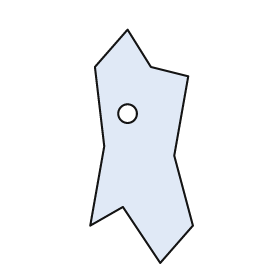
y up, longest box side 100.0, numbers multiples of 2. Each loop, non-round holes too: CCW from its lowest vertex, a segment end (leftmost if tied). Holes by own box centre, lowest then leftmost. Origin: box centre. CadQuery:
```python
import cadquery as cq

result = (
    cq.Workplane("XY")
    .moveTo(8.0, -50.0)
    .lineTo(22.0, -34.0)
    .lineTo(14.0, -4.0)
    .lineTo(20.0, 30.0)
    .lineTo(4.0, 34.0)
    .lineTo(-6.0, 50.0)
    .lineTo(-20.0, 34.0)
    .lineTo(-16.0, 0.0)
    .lineTo(-22.0, -34.0)
    .lineTo(-8.0, -26.0)
    .close()
    .moveTo(-6.0, 14.0)
    .circle(4.0)
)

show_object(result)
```